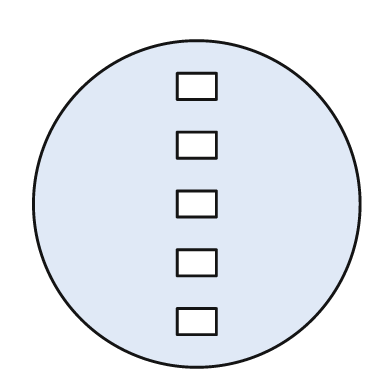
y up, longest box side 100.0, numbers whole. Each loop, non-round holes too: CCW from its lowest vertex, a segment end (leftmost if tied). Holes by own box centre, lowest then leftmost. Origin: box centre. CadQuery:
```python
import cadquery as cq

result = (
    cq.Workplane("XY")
    .moveTo(0.0, 0.0)
    .circle(50.0)
    .moveTo(-6.0, -40.0)
    .lineTo(6.0, -40.0)
    .lineTo(6.0, -32.0)
    .lineTo(-6.0, -32.0)
    .close()
    .moveTo(-6.0, -22.0)
    .lineTo(6.0, -22.0)
    .lineTo(6.0, -14.0)
    .lineTo(-6.0, -14.0)
    .close()
    .moveTo(-6.0, -4.0)
    .lineTo(6.0, -4.0)
    .lineTo(6.0, 4.0)
    .lineTo(-6.0, 4.0)
    .close()
    .moveTo(-6.0, 14.0)
    .lineTo(6.0, 14.0)
    .lineTo(6.0, 22.0)
    .lineTo(-6.0, 22.0)
    .close()
    .moveTo(-6.0, 32.0)
    .lineTo(6.0, 32.0)
    .lineTo(6.0, 40.0)
    .lineTo(-6.0, 40.0)
    .close()
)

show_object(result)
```